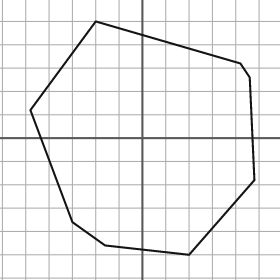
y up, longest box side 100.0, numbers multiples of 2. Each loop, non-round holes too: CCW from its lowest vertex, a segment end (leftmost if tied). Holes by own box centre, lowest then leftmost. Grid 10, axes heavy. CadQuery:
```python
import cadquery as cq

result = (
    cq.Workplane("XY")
    .moveTo(20.0, -50.0)
    .lineTo(48.0, -18.0)
    .lineTo(46.0, 26.0)
    .lineTo(42.0, 32.0)
    .lineTo(-20.0, 50.0)
    .lineTo(-48.0, 12.0)
    .lineTo(-30.0, -36.0)
    .lineTo(-16.0, -46.0)
    .close()
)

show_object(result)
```